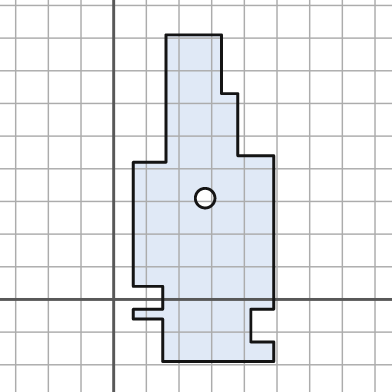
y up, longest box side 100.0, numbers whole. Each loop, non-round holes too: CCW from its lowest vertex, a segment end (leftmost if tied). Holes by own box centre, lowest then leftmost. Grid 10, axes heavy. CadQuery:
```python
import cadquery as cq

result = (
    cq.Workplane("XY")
    .moveTo(15.0, -19.0)
    .lineTo(49.0, -19.0)
    .lineTo(49.0, -13.0)
    .lineTo(42.0, -13.0)
    .lineTo(42.0, -3.0)
    .lineTo(49.0, -3.0)
    .lineTo(49.0, 44.0)
    .lineTo(38.0, 44.0)
    .lineTo(38.0, 63.0)
    .lineTo(33.0, 63.0)
    .lineTo(33.0, 81.0)
    .lineTo(16.0, 81.0)
    .lineTo(16.0, 42.0)
    .lineTo(6.0, 42.0)
    .lineTo(6.0, 4.0)
    .lineTo(15.0, 4.0)
    .lineTo(15.0, -3.0)
    .lineTo(6.0, -3.0)
    .lineTo(6.0, -6.0)
    .lineTo(15.0, -6.0)
    .close()
    .moveTo(28.0, 31.0)
    .circle(3.0)
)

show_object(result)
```